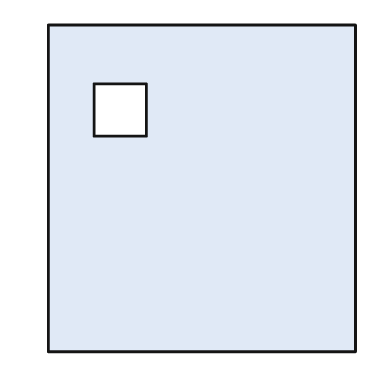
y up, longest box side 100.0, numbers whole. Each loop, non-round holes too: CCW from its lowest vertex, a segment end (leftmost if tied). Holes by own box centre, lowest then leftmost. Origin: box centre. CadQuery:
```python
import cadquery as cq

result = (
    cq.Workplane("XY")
    .moveTo(-47.0, -50.0)
    .lineTo(47.0, -50.0)
    .lineTo(47.0, 50.0)
    .lineTo(-47.0, 50.0)
    .close()
    .moveTo(-33.0, 16.0)
    .lineTo(-17.0, 16.0)
    .lineTo(-17.0, 32.0)
    .lineTo(-33.0, 32.0)
    .close()
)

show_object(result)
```